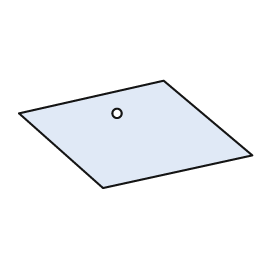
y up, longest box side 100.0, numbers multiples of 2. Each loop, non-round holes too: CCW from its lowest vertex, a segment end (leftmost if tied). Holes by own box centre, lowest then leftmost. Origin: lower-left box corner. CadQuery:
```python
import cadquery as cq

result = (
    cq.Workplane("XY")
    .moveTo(36.0, 0.0)
    .lineTo(100.0, 14.0)
    .lineTo(62.0, 46.0)
    .lineTo(0.0, 32.0)
    .close()
    .moveTo(42.0, 32.0)
    .circle(2.0)
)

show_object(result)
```